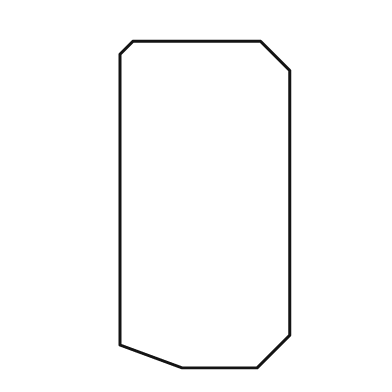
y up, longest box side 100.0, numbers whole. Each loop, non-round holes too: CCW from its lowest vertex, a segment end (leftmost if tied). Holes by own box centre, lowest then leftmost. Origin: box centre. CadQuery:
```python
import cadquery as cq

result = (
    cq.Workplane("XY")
    .moveTo(-7.0, -50.0)
    .lineTo(16.0, -50.0)
    .lineTo(26.0, -40.0)
    .lineTo(26.0, 41.0)
    .lineTo(17.0, 50.0)
    .lineTo(-22.0, 50.0)
    .lineTo(-26.0, 46.0)
    .lineTo(-26.0, -43.0)
    .close()
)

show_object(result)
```